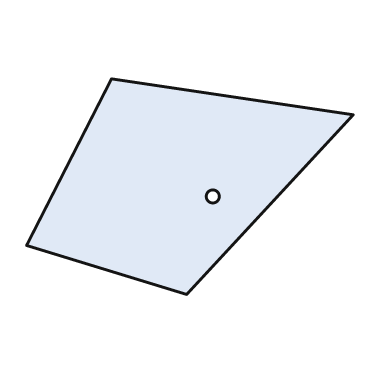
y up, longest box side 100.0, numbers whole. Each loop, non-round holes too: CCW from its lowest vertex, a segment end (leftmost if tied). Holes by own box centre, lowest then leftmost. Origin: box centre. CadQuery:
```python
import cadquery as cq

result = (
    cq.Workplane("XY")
    .moveTo(-1.0, -33.0)
    .lineTo(50.0, 22.0)
    .lineTo(-24.0, 33.0)
    .lineTo(-50.0, -18.0)
    .close()
    .moveTo(7.0, -3.0)
    .circle(2.0)
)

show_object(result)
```